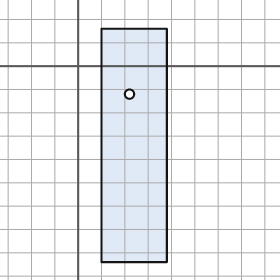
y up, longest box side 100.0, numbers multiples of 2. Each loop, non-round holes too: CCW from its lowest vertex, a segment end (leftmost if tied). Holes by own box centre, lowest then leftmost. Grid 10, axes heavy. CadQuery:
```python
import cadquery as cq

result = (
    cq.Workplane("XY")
    .moveTo(10.0, -84.0)
    .lineTo(38.0, -84.0)
    .lineTo(38.0, 16.0)
    .lineTo(10.0, 16.0)
    .close()
    .moveTo(22.0, -12.0)
    .circle(2.0)
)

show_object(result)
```